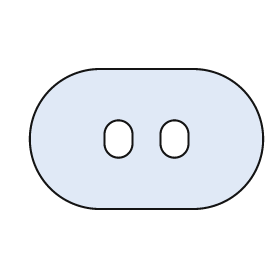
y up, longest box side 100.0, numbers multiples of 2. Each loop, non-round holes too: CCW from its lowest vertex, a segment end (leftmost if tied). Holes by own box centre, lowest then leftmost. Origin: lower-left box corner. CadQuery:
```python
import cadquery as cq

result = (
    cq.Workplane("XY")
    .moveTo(30.0, 0.0)
    .lineTo(70.0, 0.0)
    .threePointArc((100.0, 30.0), (70.0, 60.0))
    .lineTo(30.0, 60.0)
    .threePointArc((0.0, 30.0), (30.0, 0.0))
    .close()
    .moveTo(32.0, 28.0)
    .threePointArc((38.0, 22.0), (44.0, 28.0))
    .lineTo(44.0, 32.0)
    .threePointArc((38.0, 38.0), (32.0, 32.0))
    .close()
    .moveTo(56.0, 28.0)
    .threePointArc((62.0, 22.0), (68.0, 28.0))
    .lineTo(68.0, 32.0)
    .threePointArc((62.0, 38.0), (56.0, 32.0))
    .close()
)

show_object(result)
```